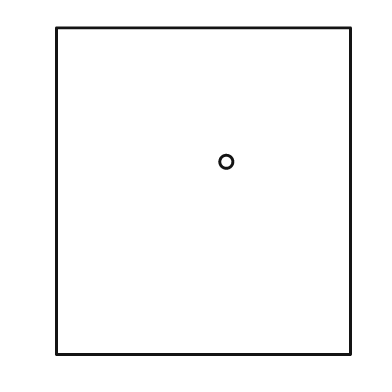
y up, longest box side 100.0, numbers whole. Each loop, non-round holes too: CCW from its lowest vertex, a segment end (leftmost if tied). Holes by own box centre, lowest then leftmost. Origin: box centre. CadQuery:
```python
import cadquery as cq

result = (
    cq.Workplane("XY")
    .moveTo(-45.0, -50.0)
    .lineTo(45.0, -50.0)
    .lineTo(45.0, 50.0)
    .lineTo(-45.0, 50.0)
    .close()
    .moveTo(7.0, 9.0)
    .circle(2.0)
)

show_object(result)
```